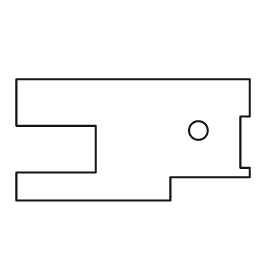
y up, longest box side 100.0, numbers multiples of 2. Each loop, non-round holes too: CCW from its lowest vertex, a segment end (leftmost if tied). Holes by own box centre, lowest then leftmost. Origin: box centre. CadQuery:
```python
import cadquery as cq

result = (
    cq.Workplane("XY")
    .moveTo(-50.0, -26.0)
    .lineTo(16.0, -26.0)
    .lineTo(16.0, -16.0)
    .lineTo(50.0, -16.0)
    .lineTo(50.0, -12.0)
    .lineTo(46.0, -12.0)
    .lineTo(46.0, 10.0)
    .lineTo(50.0, 10.0)
    .lineTo(50.0, 26.0)
    .lineTo(-50.0, 26.0)
    .lineTo(-50.0, 6.0)
    .lineTo(-16.0, 6.0)
    .lineTo(-16.0, -14.0)
    .lineTo(-50.0, -14.0)
    .close()
    .moveTo(28.0, 4.0)
    .circle(4.0)
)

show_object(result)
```